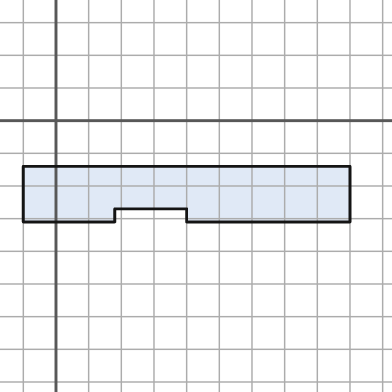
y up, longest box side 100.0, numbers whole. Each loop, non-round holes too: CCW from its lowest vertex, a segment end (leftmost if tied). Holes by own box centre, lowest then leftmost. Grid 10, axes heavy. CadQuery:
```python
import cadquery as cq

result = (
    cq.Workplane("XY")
    .moveTo(-10.0, -31.0)
    .lineTo(18.0, -31.0)
    .lineTo(18.0, -27.0)
    .lineTo(40.0, -27.0)
    .lineTo(40.0, -31.0)
    .lineTo(90.0, -31.0)
    .lineTo(90.0, -14.0)
    .lineTo(-10.0, -14.0)
    .close()
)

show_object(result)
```